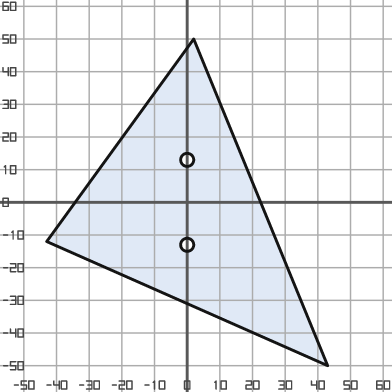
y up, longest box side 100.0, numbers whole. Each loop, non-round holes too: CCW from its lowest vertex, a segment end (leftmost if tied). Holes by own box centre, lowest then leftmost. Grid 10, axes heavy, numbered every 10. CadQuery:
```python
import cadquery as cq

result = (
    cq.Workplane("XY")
    .moveTo(43.0, -50.0)
    .lineTo(2.0, 50.0)
    .lineTo(-43.0, -12.0)
    .close()
    .moveTo(0.0, -13.0)
    .circle(2.0)
    .moveTo(0.0, 13.0)
    .circle(2.0)
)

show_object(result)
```